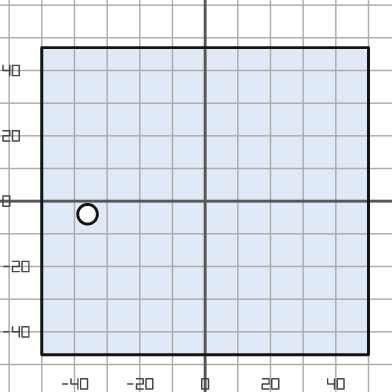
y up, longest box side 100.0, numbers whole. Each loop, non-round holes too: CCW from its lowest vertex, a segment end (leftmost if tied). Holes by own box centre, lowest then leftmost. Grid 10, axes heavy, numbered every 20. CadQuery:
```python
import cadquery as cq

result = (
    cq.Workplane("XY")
    .moveTo(-50.0, -47.0)
    .lineTo(50.0, -47.0)
    .lineTo(50.0, 47.0)
    .lineTo(-50.0, 47.0)
    .close()
    .moveTo(-36.0, -4.0)
    .circle(3.0)
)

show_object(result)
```